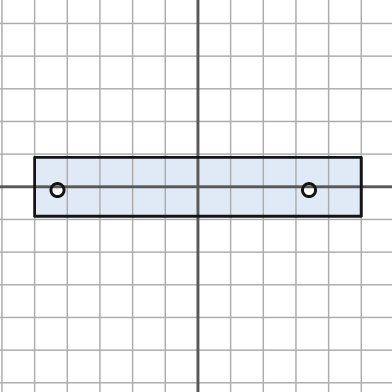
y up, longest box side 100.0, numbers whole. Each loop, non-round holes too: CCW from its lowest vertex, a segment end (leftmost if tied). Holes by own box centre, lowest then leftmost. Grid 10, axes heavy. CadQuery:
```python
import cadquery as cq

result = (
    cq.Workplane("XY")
    .moveTo(-50.0, -9.0)
    .lineTo(50.0, -9.0)
    .lineTo(50.0, 9.0)
    .lineTo(-50.0, 9.0)
    .close()
    .moveTo(-43.0, -1.0)
    .circle(2.0)
    .moveTo(34.0, -1.0)
    .circle(2.0)
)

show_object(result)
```